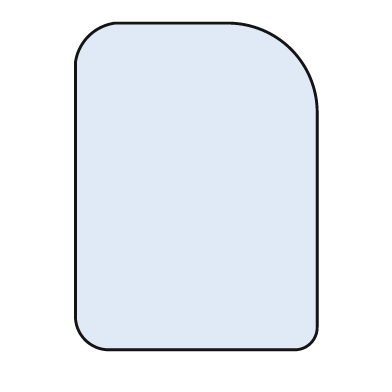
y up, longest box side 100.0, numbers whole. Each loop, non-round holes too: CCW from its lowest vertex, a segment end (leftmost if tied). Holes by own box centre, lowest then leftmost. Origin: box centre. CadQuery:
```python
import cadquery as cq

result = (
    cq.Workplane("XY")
    .moveTo(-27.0, -50.0)
    .lineTo(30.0, -50.0)
    .threePointArc((35.0, -48.0), (37.0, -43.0))
    .lineTo(37.0, 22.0)
    .threePointArc((29.0, 42.0), (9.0, 50.0))
    .lineTo(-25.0, 50.0)
    .threePointArc((-33.0, 46.0), (-37.0, 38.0))
    .lineTo(-37.0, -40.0)
    .threePointArc((-34.0, -47.0), (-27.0, -50.0))
    .close()
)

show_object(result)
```